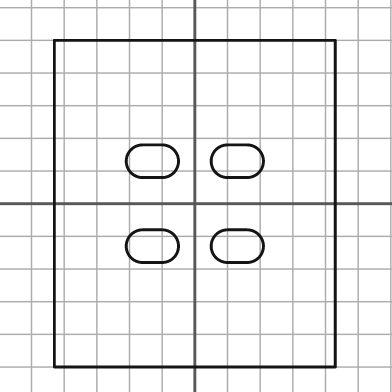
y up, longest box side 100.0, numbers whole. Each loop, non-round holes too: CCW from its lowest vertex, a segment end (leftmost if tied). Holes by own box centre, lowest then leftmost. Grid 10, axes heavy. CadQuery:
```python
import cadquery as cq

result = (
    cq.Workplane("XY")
    .moveTo(-43.0, -50.0)
    .lineTo(43.0, -50.0)
    .lineTo(43.0, 50.0)
    .lineTo(-43.0, 50.0)
    .close()
    .moveTo(-16.0, -18.0)
    .lineTo(-10.0, -18.0)
    .threePointArc((-5.0, -13.0), (-10.0, -8.0))
    .lineTo(-16.0, -8.0)
    .threePointArc((-21.0, -13.0), (-16.0, -18.0))
    .close()
    .moveTo(10.0, -18.0)
    .lineTo(16.0, -18.0)
    .threePointArc((21.0, -13.0), (16.0, -8.0))
    .lineTo(10.0, -8.0)
    .threePointArc((5.0, -13.0), (10.0, -18.0))
    .close()
    .moveTo(-16.0, 8.0)
    .lineTo(-10.0, 8.0)
    .threePointArc((-5.0, 13.0), (-10.0, 18.0))
    .lineTo(-16.0, 18.0)
    .threePointArc((-21.0, 13.0), (-16.0, 8.0))
    .close()
    .moveTo(10.0, 8.0)
    .lineTo(16.0, 8.0)
    .threePointArc((21.0, 13.0), (16.0, 18.0))
    .lineTo(10.0, 18.0)
    .threePointArc((5.0, 13.0), (10.0, 8.0))
    .close()
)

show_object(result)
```